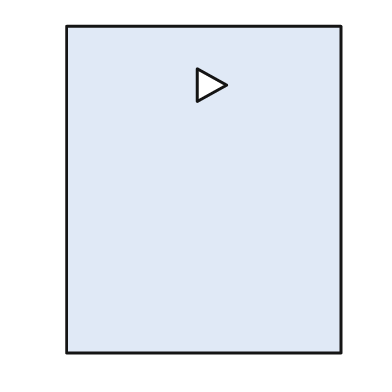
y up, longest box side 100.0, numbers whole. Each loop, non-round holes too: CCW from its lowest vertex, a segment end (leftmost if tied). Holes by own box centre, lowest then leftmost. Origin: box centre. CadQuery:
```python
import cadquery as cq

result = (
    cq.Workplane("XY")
    .moveTo(-42.0, -50.0)
    .lineTo(42.0, -50.0)
    .lineTo(42.0, 50.0)
    .lineTo(-42.0, 50.0)
    .close()
    .moveTo(-2.0, 27.0)
    .lineTo(7.0, 32.0)
    .lineTo(-2.0, 37.0)
    .close()
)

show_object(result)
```